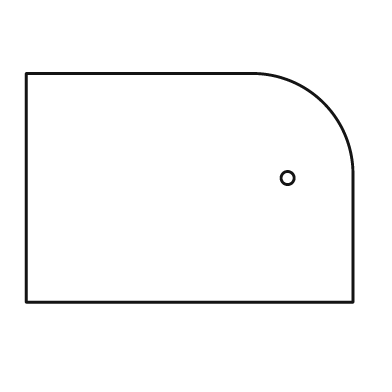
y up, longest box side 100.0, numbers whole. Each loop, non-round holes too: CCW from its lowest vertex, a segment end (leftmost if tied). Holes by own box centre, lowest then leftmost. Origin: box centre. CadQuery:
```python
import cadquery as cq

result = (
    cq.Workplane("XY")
    .moveTo(-50.0, -35.0)
    .lineTo(50.0, -35.0)
    .lineTo(50.0, 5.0)
    .threePointArc((41.0, 26.0), (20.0, 35.0))
    .lineTo(-50.0, 35.0)
    .close()
    .moveTo(30.0, 3.0)
    .circle(2.0)
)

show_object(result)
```